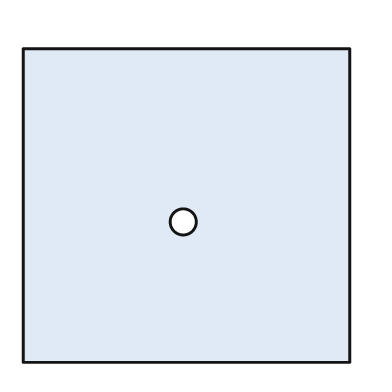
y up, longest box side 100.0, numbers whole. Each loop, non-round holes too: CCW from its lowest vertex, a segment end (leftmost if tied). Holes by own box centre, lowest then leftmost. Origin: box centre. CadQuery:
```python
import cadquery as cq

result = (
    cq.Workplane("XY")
    .moveTo(-50.0, -48.0)
    .lineTo(50.0, -48.0)
    .lineTo(50.0, 48.0)
    .lineTo(-50.0, 48.0)
    .close()
    .moveTo(-1.0, -5.0)
    .circle(4.0)
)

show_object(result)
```